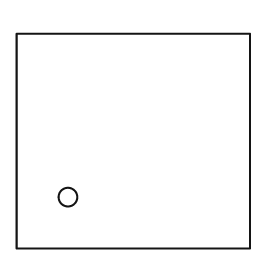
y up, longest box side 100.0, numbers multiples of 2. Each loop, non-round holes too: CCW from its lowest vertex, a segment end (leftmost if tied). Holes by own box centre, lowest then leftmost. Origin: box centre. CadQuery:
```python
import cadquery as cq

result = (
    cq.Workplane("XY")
    .moveTo(-50.0, -46.0)
    .lineTo(50.0, -46.0)
    .lineTo(50.0, 46.0)
    .lineTo(-50.0, 46.0)
    .close()
    .moveTo(-28.0, -24.0)
    .circle(4.0)
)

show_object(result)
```